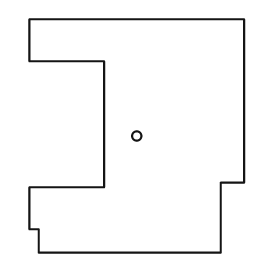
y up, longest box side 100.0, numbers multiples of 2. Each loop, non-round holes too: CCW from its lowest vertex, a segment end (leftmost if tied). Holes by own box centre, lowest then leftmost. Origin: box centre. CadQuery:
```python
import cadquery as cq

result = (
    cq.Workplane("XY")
    .moveTo(-42.0, -50.0)
    .lineTo(36.0, -50.0)
    .lineTo(36.0, -20.0)
    .lineTo(46.0, -20.0)
    .lineTo(46.0, 50.0)
    .lineTo(-46.0, 50.0)
    .lineTo(-46.0, 32.0)
    .lineTo(-14.0, 32.0)
    .lineTo(-14.0, -22.0)
    .lineTo(-46.0, -22.0)
    .lineTo(-46.0, -40.0)
    .lineTo(-42.0, -40.0)
    .close()
    .moveTo(0.0, 0.0)
    .circle(2.0)
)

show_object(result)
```